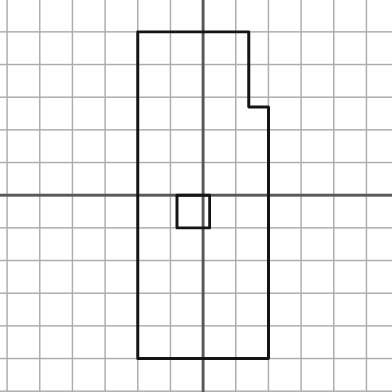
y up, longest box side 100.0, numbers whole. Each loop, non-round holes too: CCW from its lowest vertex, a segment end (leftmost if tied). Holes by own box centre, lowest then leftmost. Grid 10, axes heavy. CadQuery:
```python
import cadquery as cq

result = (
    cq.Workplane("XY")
    .moveTo(-20.0, -50.0)
    .lineTo(20.0, -50.0)
    .lineTo(20.0, 27.0)
    .lineTo(14.0, 27.0)
    .lineTo(14.0, 50.0)
    .lineTo(-20.0, 50.0)
    .close()
    .moveTo(-8.0, -10.0)
    .lineTo(2.0, -10.0)
    .lineTo(2.0, 0.0)
    .lineTo(-8.0, 0.0)
    .close()
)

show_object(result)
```